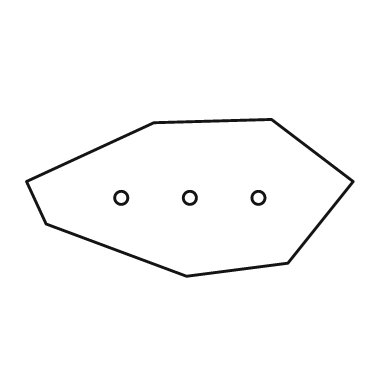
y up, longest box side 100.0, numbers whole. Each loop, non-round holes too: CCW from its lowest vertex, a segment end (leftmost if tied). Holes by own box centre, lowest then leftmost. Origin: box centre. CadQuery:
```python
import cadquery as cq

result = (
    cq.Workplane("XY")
    .moveTo(-1.0, -24.0)
    .lineTo(30.0, -20.0)
    .lineTo(50.0, 5.0)
    .lineTo(25.0, 24.0)
    .lineTo(-11.0, 23.0)
    .lineTo(-50.0, 5.0)
    .lineTo(-44.0, -8.0)
    .close()
    .moveTo(-21.0, 0.0)
    .circle(2.0)
    .moveTo(0.0, 0.0)
    .circle(2.0)
    .moveTo(21.0, 0.0)
    .circle(2.0)
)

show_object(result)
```